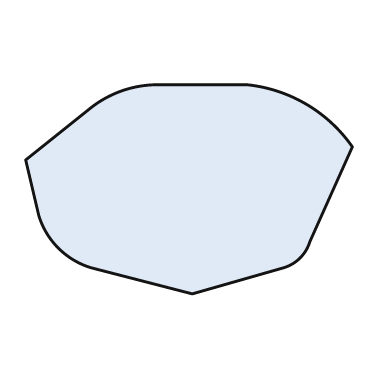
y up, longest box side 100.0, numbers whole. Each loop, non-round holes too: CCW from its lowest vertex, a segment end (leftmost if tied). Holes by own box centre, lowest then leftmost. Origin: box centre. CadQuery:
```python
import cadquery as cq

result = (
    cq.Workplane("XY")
    .moveTo(1.0, -32.0)
    .lineTo(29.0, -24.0)
    .threePointArc((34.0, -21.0), (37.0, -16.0))
    .lineTo(50.0, 13.0)
    .threePointArc((36.0, 26.0), (18.0, 32.0))
    .lineTo(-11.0, 32.0)
    .threePointArc((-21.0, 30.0), (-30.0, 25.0))
    .lineTo(-50.0, 9.0)
    .lineTo(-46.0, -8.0)
    .threePointArc((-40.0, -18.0), (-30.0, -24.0))
    .close()
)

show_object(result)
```